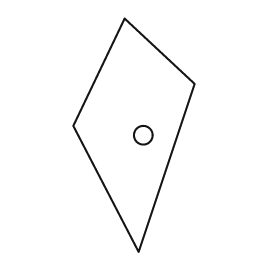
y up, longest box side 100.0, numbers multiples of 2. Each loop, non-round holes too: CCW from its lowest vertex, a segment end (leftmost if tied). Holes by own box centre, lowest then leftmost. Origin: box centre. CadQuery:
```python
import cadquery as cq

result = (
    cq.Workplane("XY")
    .moveTo(2.0, -50.0)
    .lineTo(26.0, 22.0)
    .lineTo(-4.0, 50.0)
    .lineTo(-26.0, 4.0)
    .close()
    .moveTo(4.0, 0.0)
    .circle(4.0)
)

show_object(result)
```